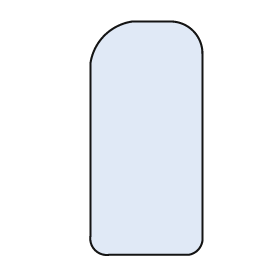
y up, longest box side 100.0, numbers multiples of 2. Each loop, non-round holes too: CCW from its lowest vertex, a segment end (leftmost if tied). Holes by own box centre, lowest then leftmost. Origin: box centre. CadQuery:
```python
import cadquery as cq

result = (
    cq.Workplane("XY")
    .moveTo(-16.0, -50.0)
    .lineTo(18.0, -50.0)
    .threePointArc((22.0, -48.0), (24.0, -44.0))
    .lineTo(24.0, 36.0)
    .threePointArc((20.0, 46.0), (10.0, 50.0))
    .lineTo(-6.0, 50.0)
    .threePointArc((-18.0, 44.0), (-24.0, 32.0))
    .lineTo(-24.0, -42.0)
    .threePointArc((-22.0, -48.0), (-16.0, -50.0))
    .close()
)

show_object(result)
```